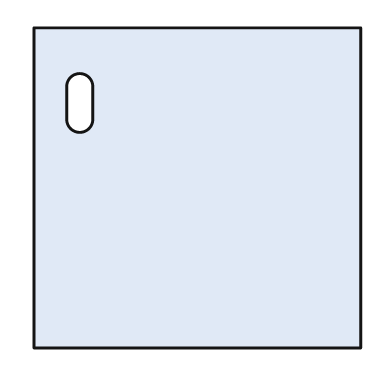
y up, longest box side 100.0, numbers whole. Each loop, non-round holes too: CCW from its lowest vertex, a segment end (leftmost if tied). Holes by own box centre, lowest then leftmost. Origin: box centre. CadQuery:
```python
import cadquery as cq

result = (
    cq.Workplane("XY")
    .moveTo(-50.0, -49.0)
    .lineTo(50.0, -49.0)
    .lineTo(50.0, 49.0)
    .lineTo(-50.0, 49.0)
    .close()
    .moveTo(-40.0, 21.0)
    .threePointArc((-36.0, 17.0), (-32.0, 21.0))
    .lineTo(-32.0, 31.0)
    .threePointArc((-36.0, 35.0), (-40.0, 31.0))
    .close()
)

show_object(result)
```